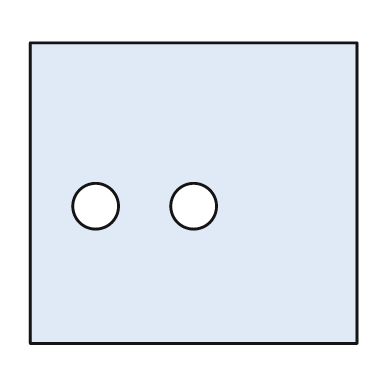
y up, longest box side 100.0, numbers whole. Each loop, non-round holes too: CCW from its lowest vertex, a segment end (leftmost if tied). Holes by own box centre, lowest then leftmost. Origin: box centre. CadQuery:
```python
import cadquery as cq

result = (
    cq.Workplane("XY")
    .moveTo(-50.0, -46.0)
    .lineTo(50.0, -46.0)
    .lineTo(50.0, 46.0)
    .lineTo(-50.0, 46.0)
    .close()
    .moveTo(-30.0, -4.0)
    .circle(7.0)
    .moveTo(0.0, -4.0)
    .circle(7.0)
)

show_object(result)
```